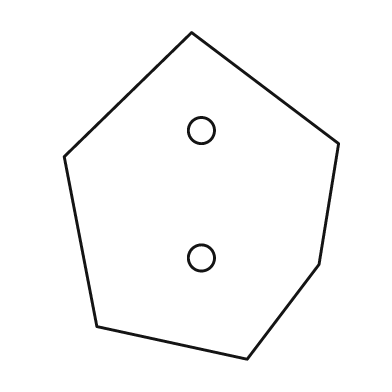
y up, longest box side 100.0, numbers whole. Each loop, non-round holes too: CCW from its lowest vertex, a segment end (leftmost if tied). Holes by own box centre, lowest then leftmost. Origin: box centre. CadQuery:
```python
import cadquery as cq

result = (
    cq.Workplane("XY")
    .moveTo(14.0, -50.0)
    .lineTo(36.0, -21.0)
    .lineTo(42.0, 16.0)
    .lineTo(-3.0, 50.0)
    .lineTo(-42.0, 12.0)
    .lineTo(-32.0, -40.0)
    .close()
    .moveTo(0.0, -19.0)
    .circle(4.0)
    .moveTo(0.0, 20.0)
    .circle(4.0)
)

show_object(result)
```